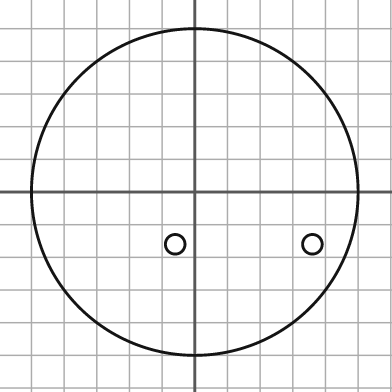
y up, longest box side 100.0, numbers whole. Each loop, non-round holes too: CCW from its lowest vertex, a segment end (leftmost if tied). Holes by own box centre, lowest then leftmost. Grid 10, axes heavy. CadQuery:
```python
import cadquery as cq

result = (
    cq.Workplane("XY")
    .moveTo(0.0, 0.0)
    .circle(50.0)
    .moveTo(-6.0, -16.0)
    .circle(3.0)
    .moveTo(36.0, -16.0)
    .circle(3.0)
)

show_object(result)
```